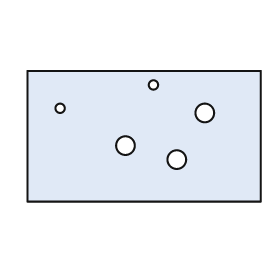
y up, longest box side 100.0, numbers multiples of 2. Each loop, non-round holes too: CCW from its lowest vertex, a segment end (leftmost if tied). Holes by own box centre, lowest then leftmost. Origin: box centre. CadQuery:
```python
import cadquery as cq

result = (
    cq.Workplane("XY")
    .moveTo(-50.0, -28.0)
    .lineTo(50.0, -28.0)
    .lineTo(50.0, 28.0)
    .lineTo(-50.0, 28.0)
    .close()
    .moveTo(14.0, -10.0)
    .circle(4.0)
    .moveTo(-8.0, -4.0)
    .circle(4.0)
    .moveTo(26.0, 10.0)
    .circle(4.0)
    .moveTo(-36.0, 12.0)
    .circle(2.0)
    .moveTo(4.0, 22.0)
    .circle(2.0)
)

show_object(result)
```